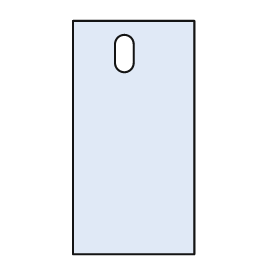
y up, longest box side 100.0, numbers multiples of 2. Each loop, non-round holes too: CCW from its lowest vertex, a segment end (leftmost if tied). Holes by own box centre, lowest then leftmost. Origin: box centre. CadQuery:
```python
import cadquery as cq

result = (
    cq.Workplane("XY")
    .moveTo(-26.0, -50.0)
    .lineTo(26.0, -50.0)
    .lineTo(26.0, 50.0)
    .lineTo(-26.0, 50.0)
    .close()
    .moveTo(-8.0, 32.0)
    .threePointArc((-4.0, 28.0), (0.0, 32.0))
    .lineTo(0.0, 40.0)
    .threePointArc((-4.0, 44.0), (-8.0, 40.0))
    .close()
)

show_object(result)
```